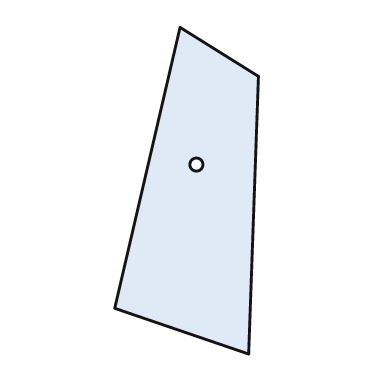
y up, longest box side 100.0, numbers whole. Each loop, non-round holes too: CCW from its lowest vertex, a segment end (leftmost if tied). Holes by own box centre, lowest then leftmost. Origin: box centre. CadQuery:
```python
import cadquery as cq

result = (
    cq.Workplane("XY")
    .moveTo(19.0, -50.0)
    .lineTo(22.0, 35.0)
    .lineTo(-2.0, 50.0)
    .lineTo(-22.0, -36.0)
    .close()
    .moveTo(3.0, 8.0)
    .circle(2.0)
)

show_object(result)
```